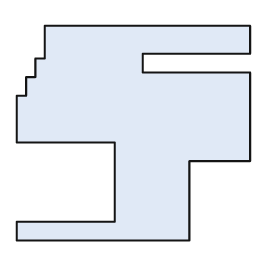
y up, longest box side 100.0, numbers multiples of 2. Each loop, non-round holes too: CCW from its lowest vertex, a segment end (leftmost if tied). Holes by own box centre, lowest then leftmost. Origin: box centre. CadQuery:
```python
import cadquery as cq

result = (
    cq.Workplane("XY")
    .moveTo(-50.0, -46.0)
    .lineTo(24.0, -46.0)
    .lineTo(24.0, -12.0)
    .lineTo(50.0, -12.0)
    .lineTo(50.0, 26.0)
    .lineTo(4.0, 26.0)
    .lineTo(4.0, 34.0)
    .lineTo(50.0, 34.0)
    .lineTo(50.0, 46.0)
    .lineTo(-38.0, 46.0)
    .lineTo(-38.0, 32.0)
    .lineTo(-42.0, 32.0)
    .lineTo(-42.0, 24.0)
    .lineTo(-46.0, 24.0)
    .lineTo(-46.0, 16.0)
    .lineTo(-50.0, 16.0)
    .lineTo(-50.0, -4.0)
    .lineTo(-8.0, -4.0)
    .lineTo(-8.0, -38.0)
    .lineTo(-50.0, -38.0)
    .close()
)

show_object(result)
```